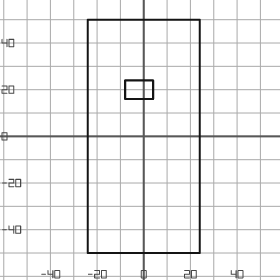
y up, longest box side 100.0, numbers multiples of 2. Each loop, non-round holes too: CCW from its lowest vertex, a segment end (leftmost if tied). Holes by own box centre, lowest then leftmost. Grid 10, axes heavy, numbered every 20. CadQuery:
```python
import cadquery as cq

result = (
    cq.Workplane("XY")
    .moveTo(-24.0, -50.0)
    .lineTo(24.0, -50.0)
    .lineTo(24.0, 50.0)
    .lineTo(-24.0, 50.0)
    .close()
    .moveTo(-8.0, 16.0)
    .lineTo(4.0, 16.0)
    .lineTo(4.0, 24.0)
    .lineTo(-8.0, 24.0)
    .close()
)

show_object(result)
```